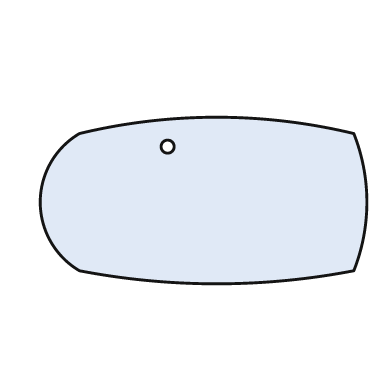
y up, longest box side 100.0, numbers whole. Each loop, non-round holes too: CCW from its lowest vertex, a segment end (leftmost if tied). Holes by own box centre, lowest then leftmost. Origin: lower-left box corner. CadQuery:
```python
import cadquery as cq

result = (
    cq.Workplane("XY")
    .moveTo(12.0, 4.0)
    .threePointArc((54.0, 0.0), (96.0, 4.0))
    .threePointArc((100.0, 25.0), (96.0, 46.0))
    .threePointArc((54.0, 51.0), (12.0, 46.0))
    .threePointArc((0.0, 25.0), (12.0, 4.0))
    .close()
    .moveTo(39.0, 42.0)
    .circle(2.0)
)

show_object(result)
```